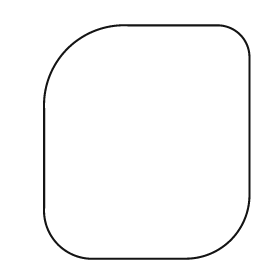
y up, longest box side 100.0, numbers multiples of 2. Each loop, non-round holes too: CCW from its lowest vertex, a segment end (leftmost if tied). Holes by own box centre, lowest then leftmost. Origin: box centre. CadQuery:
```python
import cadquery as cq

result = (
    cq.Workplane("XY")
    .moveTo(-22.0, -50.0)
    .lineTo(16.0, -50.0)
    .threePointArc((36.0, -42.0), (44.0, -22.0))
    .lineTo(44.0, 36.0)
    .threePointArc((40.0, 46.0), (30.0, 50.0))
    .lineTo(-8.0, 50.0)
    .threePointArc((-34.0, 40.0), (-44.0, 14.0))
    .lineTo(-44.0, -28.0)
    .threePointArc((-38.0, -44.0), (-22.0, -50.0))
    .close()
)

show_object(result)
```